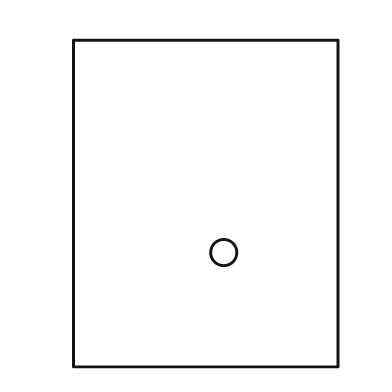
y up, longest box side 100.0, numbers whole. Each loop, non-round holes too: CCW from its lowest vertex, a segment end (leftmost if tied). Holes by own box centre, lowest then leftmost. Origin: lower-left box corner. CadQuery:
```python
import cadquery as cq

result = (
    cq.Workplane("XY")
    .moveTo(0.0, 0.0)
    .lineTo(81.0, 0.0)
    .lineTo(81.0, 100.0)
    .lineTo(0.0, 100.0)
    .close()
    .moveTo(46.0, 35.0)
    .circle(4.0)
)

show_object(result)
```